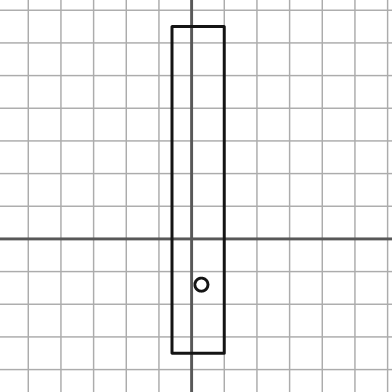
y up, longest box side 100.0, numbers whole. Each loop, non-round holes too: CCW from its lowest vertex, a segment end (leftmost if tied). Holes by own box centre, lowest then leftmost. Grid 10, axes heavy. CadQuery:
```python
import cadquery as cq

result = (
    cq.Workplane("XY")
    .moveTo(-6.0, -35.0)
    .lineTo(10.0, -35.0)
    .lineTo(10.0, 65.0)
    .lineTo(-6.0, 65.0)
    .close()
    .moveTo(3.0, -14.0)
    .circle(2.0)
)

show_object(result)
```